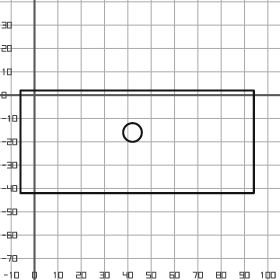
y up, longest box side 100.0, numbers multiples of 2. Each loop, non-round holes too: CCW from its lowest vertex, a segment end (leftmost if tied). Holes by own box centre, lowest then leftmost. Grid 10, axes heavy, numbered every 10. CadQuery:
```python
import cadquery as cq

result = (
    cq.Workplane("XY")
    .moveTo(-6.0, -42.0)
    .lineTo(94.0, -42.0)
    .lineTo(94.0, 2.0)
    .lineTo(-6.0, 2.0)
    .close()
    .moveTo(42.0, -16.0)
    .circle(4.0)
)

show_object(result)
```